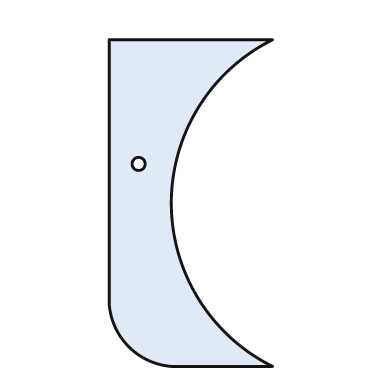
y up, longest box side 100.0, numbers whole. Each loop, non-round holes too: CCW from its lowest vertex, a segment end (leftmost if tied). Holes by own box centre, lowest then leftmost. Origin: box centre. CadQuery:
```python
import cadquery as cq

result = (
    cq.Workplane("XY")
    .moveTo(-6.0, -50.0)
    .lineTo(25.0, -50.0)
    .threePointArc((-6.0, 0.0), (25.0, 50.0))
    .lineTo(-25.0, 50.0)
    .lineTo(-25.0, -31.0)
    .threePointArc((-19.0, -44.0), (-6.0, -50.0))
    .close()
    .moveTo(-16.0, 12.0)
    .circle(2.0)
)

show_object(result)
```